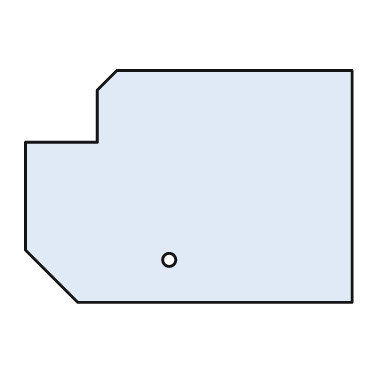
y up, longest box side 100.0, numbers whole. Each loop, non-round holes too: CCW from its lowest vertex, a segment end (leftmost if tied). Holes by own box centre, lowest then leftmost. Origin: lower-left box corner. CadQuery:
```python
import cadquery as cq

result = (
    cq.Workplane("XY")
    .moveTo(16.0, 0.0)
    .lineTo(100.0, 0.0)
    .lineTo(100.0, 71.0)
    .lineTo(28.0, 71.0)
    .lineTo(22.0, 65.0)
    .lineTo(22.0, 49.0)
    .lineTo(0.0, 49.0)
    .lineTo(0.0, 16.0)
    .close()
    .moveTo(44.0, 13.0)
    .circle(2.0)
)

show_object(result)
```